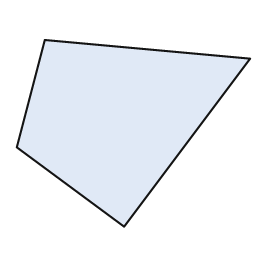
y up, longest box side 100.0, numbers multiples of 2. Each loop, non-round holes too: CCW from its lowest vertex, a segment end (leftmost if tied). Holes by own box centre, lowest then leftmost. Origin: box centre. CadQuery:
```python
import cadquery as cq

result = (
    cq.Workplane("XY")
    .moveTo(-4.0, -40.0)
    .lineTo(50.0, 32.0)
    .lineTo(-38.0, 40.0)
    .lineTo(-50.0, -6.0)
    .close()
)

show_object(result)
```